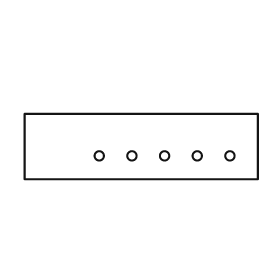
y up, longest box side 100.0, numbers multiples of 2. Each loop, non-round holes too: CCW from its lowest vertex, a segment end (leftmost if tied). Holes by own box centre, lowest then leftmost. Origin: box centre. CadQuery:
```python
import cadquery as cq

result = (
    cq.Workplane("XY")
    .moveTo(-50.0, -14.0)
    .lineTo(50.0, -14.0)
    .lineTo(50.0, 14.0)
    .lineTo(-50.0, 14.0)
    .close()
    .moveTo(-18.0, -4.0)
    .circle(2.0)
    .moveTo(-4.0, -4.0)
    .circle(2.0)
    .moveTo(10.0, -4.0)
    .circle(2.0)
    .moveTo(24.0, -4.0)
    .circle(2.0)
    .moveTo(38.0, -4.0)
    .circle(2.0)
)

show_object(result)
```